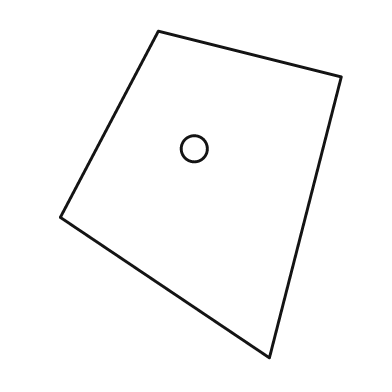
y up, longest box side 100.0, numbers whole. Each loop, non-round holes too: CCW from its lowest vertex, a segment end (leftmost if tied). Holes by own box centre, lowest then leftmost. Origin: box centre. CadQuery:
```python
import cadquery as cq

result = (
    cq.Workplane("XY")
    .moveTo(21.0, -50.0)
    .lineTo(43.0, 36.0)
    .lineTo(-13.0, 50.0)
    .lineTo(-43.0, -7.0)
    .close()
    .moveTo(-2.0, 14.0)
    .circle(4.0)
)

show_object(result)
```